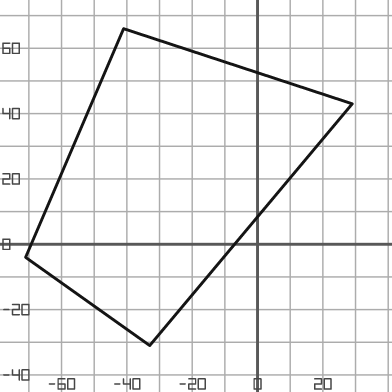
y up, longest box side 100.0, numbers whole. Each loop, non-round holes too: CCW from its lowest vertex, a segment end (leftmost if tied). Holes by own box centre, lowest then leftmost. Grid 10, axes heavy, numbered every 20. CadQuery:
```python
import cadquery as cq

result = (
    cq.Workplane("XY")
    .moveTo(-33.0, -31.0)
    .lineTo(29.0, 43.0)
    .lineTo(-41.0, 66.0)
    .lineTo(-71.0, -4.0)
    .close()
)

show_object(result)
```